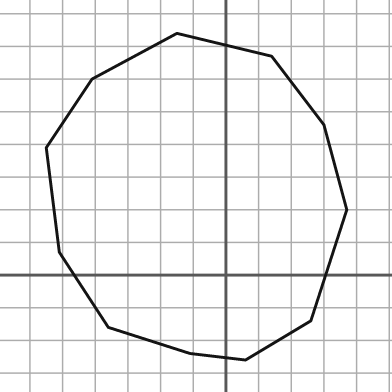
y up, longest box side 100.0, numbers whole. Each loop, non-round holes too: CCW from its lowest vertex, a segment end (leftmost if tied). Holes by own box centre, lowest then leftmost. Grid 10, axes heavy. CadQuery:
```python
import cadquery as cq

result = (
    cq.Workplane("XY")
    .moveTo(6.0, -26.0)
    .lineTo(26.0, -14.0)
    .lineTo(37.0, 20.0)
    .lineTo(30.0, 46.0)
    .lineTo(14.0, 67.0)
    .lineTo(-15.0, 74.0)
    .lineTo(-41.0, 60.0)
    .lineTo(-55.0, 39.0)
    .lineTo(-51.0, 7.0)
    .lineTo(-36.0, -16.0)
    .lineTo(-11.0, -24.0)
    .close()
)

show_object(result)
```